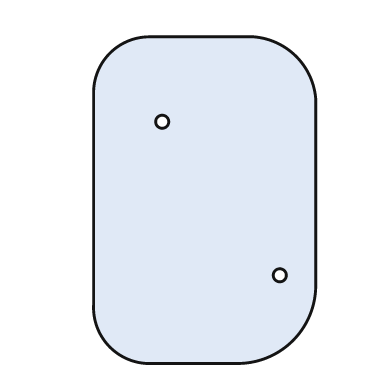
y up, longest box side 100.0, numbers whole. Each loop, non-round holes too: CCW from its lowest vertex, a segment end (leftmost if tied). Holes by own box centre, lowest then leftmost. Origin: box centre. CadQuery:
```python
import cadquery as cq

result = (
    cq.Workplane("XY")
    .moveTo(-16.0, -50.0)
    .lineTo(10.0, -50.0)
    .threePointArc((27.0, -43.0), (34.0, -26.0))
    .lineTo(34.0, 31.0)
    .threePointArc((28.0, 44.0), (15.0, 50.0))
    .lineTo(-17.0, 50.0)
    .threePointArc((-29.0, 45.0), (-34.0, 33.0))
    .lineTo(-34.0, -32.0)
    .threePointArc((-29.0, -45.0), (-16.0, -50.0))
    .close()
    .moveTo(23.0, -23.0)
    .circle(2.0)
    .moveTo(-13.0, 24.0)
    .circle(2.0)
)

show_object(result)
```